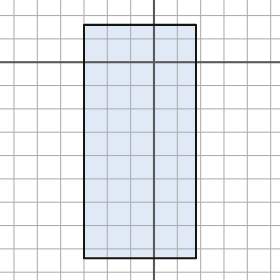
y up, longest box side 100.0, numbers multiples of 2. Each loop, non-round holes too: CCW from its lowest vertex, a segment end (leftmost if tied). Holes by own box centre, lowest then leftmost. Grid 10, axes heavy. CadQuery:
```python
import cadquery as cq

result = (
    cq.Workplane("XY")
    .moveTo(-30.0, -84.0)
    .lineTo(18.0, -84.0)
    .lineTo(18.0, 16.0)
    .lineTo(-30.0, 16.0)
    .close()
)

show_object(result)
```